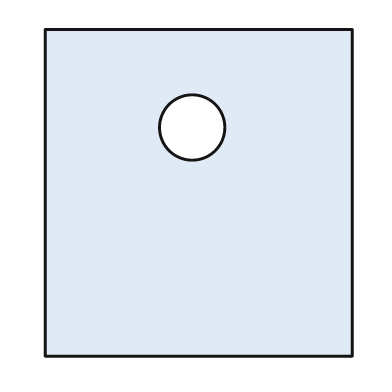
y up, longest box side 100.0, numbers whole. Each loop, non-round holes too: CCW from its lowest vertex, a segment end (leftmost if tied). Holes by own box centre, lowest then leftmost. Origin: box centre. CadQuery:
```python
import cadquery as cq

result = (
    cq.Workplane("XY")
    .moveTo(-47.0, -50.0)
    .lineTo(47.0, -50.0)
    .lineTo(47.0, 50.0)
    .lineTo(-47.0, 50.0)
    .close()
    .moveTo(-2.0, 20.0)
    .circle(10.0)
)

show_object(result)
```